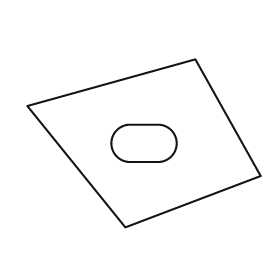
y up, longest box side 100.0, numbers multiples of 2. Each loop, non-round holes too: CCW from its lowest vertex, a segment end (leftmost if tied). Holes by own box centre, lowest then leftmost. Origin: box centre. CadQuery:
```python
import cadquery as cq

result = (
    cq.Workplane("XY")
    .moveTo(-8.0, -36.0)
    .lineTo(50.0, -14.0)
    .lineTo(22.0, 36.0)
    .lineTo(-50.0, 16.0)
    .close()
    .moveTo(-6.0, -8.0)
    .lineTo(6.0, -8.0)
    .threePointArc((14.0, 0.0), (6.0, 8.0))
    .lineTo(-6.0, 8.0)
    .threePointArc((-14.0, 0.0), (-6.0, -8.0))
    .close()
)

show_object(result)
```